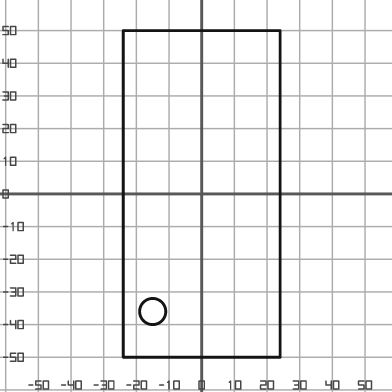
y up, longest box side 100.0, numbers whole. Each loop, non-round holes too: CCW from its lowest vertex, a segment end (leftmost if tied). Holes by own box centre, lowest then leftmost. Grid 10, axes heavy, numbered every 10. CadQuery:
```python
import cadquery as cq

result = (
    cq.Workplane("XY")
    .moveTo(-24.0, -50.0)
    .lineTo(24.0, -50.0)
    .lineTo(24.0, 50.0)
    .lineTo(-24.0, 50.0)
    .close()
    .moveTo(-15.0, -36.0)
    .circle(4.0)
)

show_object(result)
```